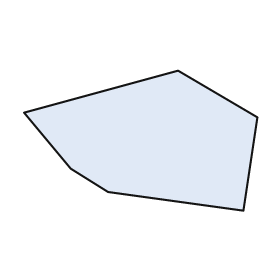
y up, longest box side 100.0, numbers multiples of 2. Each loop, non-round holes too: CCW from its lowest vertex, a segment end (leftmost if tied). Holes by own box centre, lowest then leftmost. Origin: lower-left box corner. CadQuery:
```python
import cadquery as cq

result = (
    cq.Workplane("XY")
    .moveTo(94.0, 0.0)
    .lineTo(100.0, 40.0)
    .lineTo(66.0, 60.0)
    .lineTo(0.0, 42.0)
    .lineTo(20.0, 18.0)
    .lineTo(36.0, 8.0)
    .close()
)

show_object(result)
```